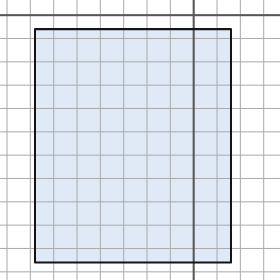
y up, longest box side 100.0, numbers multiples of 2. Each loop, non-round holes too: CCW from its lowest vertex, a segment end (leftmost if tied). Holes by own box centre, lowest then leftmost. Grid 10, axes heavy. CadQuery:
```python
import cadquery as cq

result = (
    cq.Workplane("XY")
    .moveTo(-68.0, -106.0)
    .lineTo(16.0, -106.0)
    .lineTo(16.0, -6.0)
    .lineTo(-68.0, -6.0)
    .close()
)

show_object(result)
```